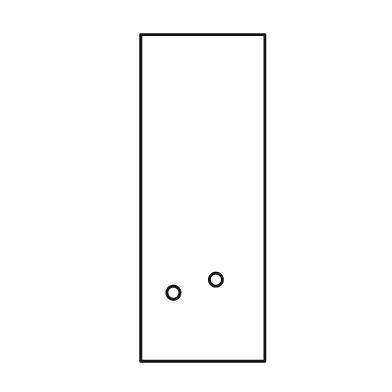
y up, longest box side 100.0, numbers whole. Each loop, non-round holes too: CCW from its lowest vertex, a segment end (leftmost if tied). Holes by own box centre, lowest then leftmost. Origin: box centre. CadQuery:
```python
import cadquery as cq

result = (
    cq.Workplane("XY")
    .moveTo(-19.0, -50.0)
    .lineTo(19.0, -50.0)
    .lineTo(19.0, 50.0)
    .lineTo(-19.0, 50.0)
    .close()
    .moveTo(-9.0, -29.0)
    .circle(2.0)
    .moveTo(4.0, -25.0)
    .circle(2.0)
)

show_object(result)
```